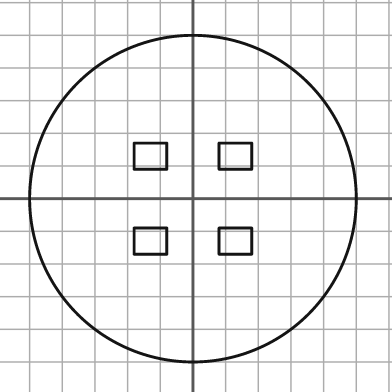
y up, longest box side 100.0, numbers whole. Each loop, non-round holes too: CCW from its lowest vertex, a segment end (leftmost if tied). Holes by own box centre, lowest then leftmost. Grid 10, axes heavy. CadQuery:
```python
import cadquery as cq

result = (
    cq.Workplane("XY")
    .moveTo(0.0, 0.0)
    .circle(50.0)
    .moveTo(-18.0, -17.0)
    .lineTo(-8.0, -17.0)
    .lineTo(-8.0, -9.0)
    .lineTo(-18.0, -9.0)
    .close()
    .moveTo(8.0, -17.0)
    .lineTo(18.0, -17.0)
    .lineTo(18.0, -9.0)
    .lineTo(8.0, -9.0)
    .close()
    .moveTo(-18.0, 9.0)
    .lineTo(-8.0, 9.0)
    .lineTo(-8.0, 17.0)
    .lineTo(-18.0, 17.0)
    .close()
    .moveTo(8.0, 9.0)
    .lineTo(18.0, 9.0)
    .lineTo(18.0, 17.0)
    .lineTo(8.0, 17.0)
    .close()
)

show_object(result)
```